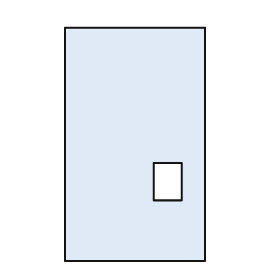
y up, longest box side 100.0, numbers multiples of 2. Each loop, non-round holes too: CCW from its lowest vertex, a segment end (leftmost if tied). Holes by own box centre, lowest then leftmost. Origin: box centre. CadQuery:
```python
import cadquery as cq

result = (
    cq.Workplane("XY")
    .moveTo(-30.0, -50.0)
    .lineTo(30.0, -50.0)
    .lineTo(30.0, 50.0)
    .lineTo(-30.0, 50.0)
    .close()
    .moveTo(8.0, -24.0)
    .lineTo(20.0, -24.0)
    .lineTo(20.0, -8.0)
    .lineTo(8.0, -8.0)
    .close()
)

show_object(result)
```